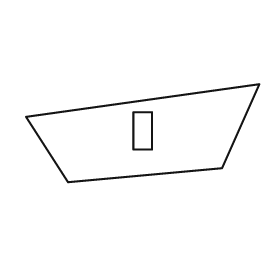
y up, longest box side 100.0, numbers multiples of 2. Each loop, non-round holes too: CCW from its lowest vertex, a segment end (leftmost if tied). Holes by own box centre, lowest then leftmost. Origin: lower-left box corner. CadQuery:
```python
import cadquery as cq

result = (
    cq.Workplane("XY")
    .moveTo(18.0, 0.0)
    .lineTo(84.0, 6.0)
    .lineTo(100.0, 42.0)
    .lineTo(0.0, 28.0)
    .close()
    .moveTo(46.0, 14.0)
    .lineTo(54.0, 14.0)
    .lineTo(54.0, 30.0)
    .lineTo(46.0, 30.0)
    .close()
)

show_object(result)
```